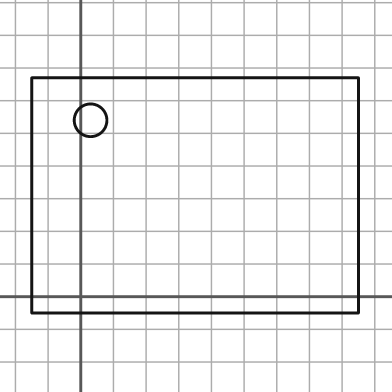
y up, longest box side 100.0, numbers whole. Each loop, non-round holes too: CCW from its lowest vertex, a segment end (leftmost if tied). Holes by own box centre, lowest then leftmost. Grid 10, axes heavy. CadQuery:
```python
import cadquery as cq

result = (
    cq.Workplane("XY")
    .moveTo(-15.0, -5.0)
    .lineTo(85.0, -5.0)
    .lineTo(85.0, 67.0)
    .lineTo(-15.0, 67.0)
    .close()
    .moveTo(3.0, 54.0)
    .circle(5.0)
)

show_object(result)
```